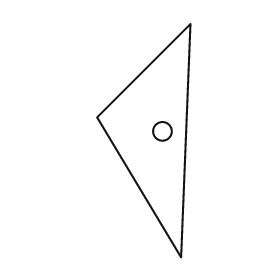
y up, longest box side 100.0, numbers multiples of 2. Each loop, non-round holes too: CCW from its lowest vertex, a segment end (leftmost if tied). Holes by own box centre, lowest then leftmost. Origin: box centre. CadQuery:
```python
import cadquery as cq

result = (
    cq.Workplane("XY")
    .moveTo(16.0, -50.0)
    .lineTo(20.0, 50.0)
    .lineTo(-20.0, 10.0)
    .close()
    .moveTo(8.0, 4.0)
    .circle(4.0)
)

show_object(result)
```